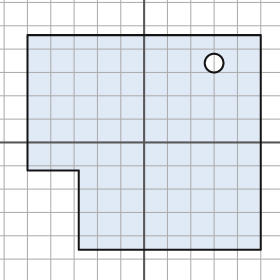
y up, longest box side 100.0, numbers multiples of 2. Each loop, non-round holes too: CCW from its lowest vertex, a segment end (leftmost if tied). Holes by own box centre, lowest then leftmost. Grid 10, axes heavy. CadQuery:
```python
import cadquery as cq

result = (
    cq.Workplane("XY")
    .moveTo(-28.0, -46.0)
    .lineTo(50.0, -46.0)
    .lineTo(50.0, 46.0)
    .lineTo(-50.0, 46.0)
    .lineTo(-50.0, -12.0)
    .lineTo(-28.0, -12.0)
    .close()
    .moveTo(30.0, 34.0)
    .circle(4.0)
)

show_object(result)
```